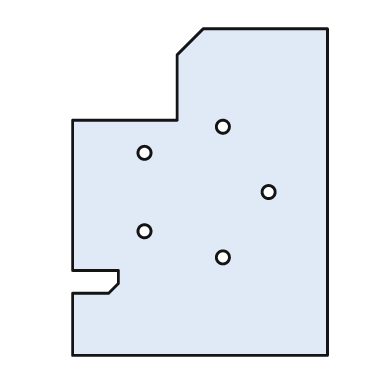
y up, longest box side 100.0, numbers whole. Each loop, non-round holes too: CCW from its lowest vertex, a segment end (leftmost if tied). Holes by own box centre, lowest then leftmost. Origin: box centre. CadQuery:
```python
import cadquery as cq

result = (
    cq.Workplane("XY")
    .moveTo(-39.0, -50.0)
    .lineTo(39.0, -50.0)
    .lineTo(39.0, 50.0)
    .lineTo(1.0, 50.0)
    .lineTo(-7.0, 42.0)
    .lineTo(-7.0, 22.0)
    .lineTo(-39.0, 22.0)
    .lineTo(-39.0, -24.0)
    .lineTo(-25.0, -24.0)
    .lineTo(-25.0, -28.0)
    .lineTo(-28.0, -31.0)
    .lineTo(-39.0, -31.0)
    .close()
    .moveTo(7.0, -20.0)
    .circle(2.0)
    .moveTo(-17.0, -12.0)
    .circle(2.0)
    .moveTo(21.0, 0.0)
    .circle(2.0)
    .moveTo(-17.0, 12.0)
    .circle(2.0)
    .moveTo(7.0, 20.0)
    .circle(2.0)
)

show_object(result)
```